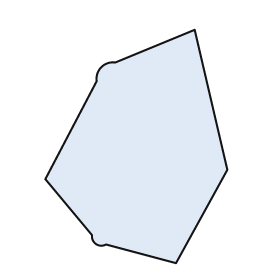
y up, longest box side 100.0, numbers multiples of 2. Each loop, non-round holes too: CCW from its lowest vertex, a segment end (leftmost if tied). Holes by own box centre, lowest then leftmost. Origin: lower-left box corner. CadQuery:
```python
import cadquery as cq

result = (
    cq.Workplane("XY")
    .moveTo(56.0, 0.0)
    .lineTo(78.0, 40.0)
    .lineTo(64.0, 100.0)
    .lineTo(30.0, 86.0)
    .threePointArc((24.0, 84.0), (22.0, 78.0))
    .lineTo(0.0, 36.0)
    .lineTo(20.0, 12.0)
    .threePointArc((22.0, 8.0), (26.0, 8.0))
    .close()
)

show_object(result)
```